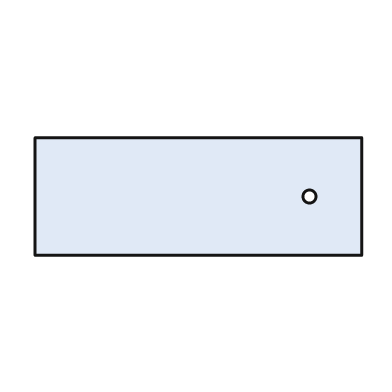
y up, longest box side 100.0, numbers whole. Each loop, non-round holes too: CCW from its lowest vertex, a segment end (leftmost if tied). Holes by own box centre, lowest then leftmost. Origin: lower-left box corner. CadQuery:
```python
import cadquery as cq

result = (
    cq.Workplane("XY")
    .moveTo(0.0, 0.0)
    .lineTo(100.0, 0.0)
    .lineTo(100.0, 36.0)
    .lineTo(0.0, 36.0)
    .close()
    .moveTo(84.0, 18.0)
    .circle(2.0)
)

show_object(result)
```